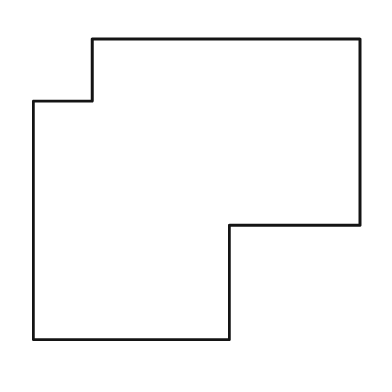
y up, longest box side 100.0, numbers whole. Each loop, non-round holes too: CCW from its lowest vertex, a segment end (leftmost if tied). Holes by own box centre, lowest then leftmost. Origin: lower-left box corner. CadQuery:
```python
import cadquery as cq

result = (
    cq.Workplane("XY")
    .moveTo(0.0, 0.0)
    .lineTo(60.0, 0.0)
    .lineTo(60.0, 35.0)
    .lineTo(100.0, 35.0)
    .lineTo(100.0, 92.0)
    .lineTo(18.0, 92.0)
    .lineTo(18.0, 73.0)
    .lineTo(0.0, 73.0)
    .close()
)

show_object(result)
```